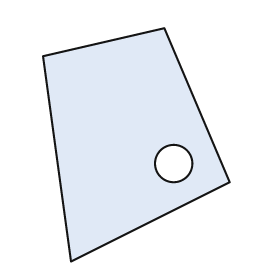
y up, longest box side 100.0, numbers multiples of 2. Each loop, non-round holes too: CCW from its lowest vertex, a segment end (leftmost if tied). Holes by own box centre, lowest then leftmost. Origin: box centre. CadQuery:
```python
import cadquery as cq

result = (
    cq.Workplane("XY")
    .moveTo(-28.0, -50.0)
    .lineTo(40.0, -16.0)
    .lineTo(12.0, 50.0)
    .lineTo(-40.0, 38.0)
    .close()
    .moveTo(16.0, -8.0)
    .circle(8.0)
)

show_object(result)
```